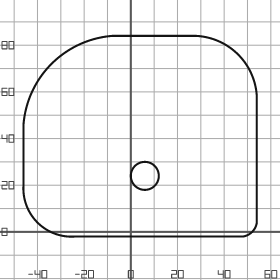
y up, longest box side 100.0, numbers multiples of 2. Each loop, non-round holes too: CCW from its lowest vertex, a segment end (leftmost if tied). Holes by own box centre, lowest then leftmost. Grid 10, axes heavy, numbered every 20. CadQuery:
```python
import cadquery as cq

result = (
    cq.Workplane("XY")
    .moveTo(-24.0, -2.0)
    .lineTo(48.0, -2.0)
    .threePointArc((52.0, 0.0), (54.0, 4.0))
    .lineTo(54.0, 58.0)
    .threePointArc((46.0, 76.0), (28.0, 84.0))
    .lineTo(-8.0, 84.0)
    .threePointArc((-34.0, 72.0), (-46.0, 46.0))
    .lineTo(-46.0, 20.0)
    .threePointArc((-40.0, 4.0), (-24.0, -2.0))
    .close()
    .moveTo(6.0, 24.0)
    .circle(6.0)
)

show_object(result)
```